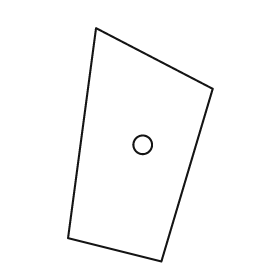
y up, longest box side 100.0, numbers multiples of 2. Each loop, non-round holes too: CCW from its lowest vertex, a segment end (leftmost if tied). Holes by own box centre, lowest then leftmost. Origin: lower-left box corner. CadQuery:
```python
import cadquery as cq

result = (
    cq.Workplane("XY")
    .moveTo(40.0, 0.0)
    .lineTo(62.0, 74.0)
    .lineTo(12.0, 100.0)
    .lineTo(0.0, 10.0)
    .close()
    .moveTo(32.0, 50.0)
    .circle(4.0)
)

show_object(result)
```